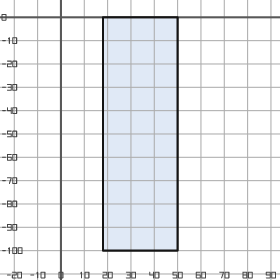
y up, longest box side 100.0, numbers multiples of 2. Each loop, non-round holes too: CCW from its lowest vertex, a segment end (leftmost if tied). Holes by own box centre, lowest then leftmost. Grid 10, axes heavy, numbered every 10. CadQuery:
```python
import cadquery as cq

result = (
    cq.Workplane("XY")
    .moveTo(18.0, -100.0)
    .lineTo(50.0, -100.0)
    .lineTo(50.0, 0.0)
    .lineTo(18.0, 0.0)
    .close()
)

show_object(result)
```